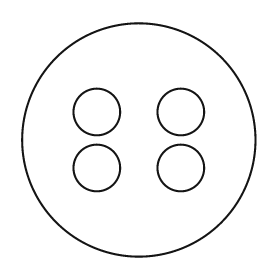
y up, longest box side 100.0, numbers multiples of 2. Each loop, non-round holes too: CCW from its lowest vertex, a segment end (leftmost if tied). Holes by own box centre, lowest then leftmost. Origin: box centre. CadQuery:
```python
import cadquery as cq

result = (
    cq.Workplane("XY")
    .moveTo(0.0, 0.0)
    .circle(50.0)
    .moveTo(-18.0, -12.0)
    .circle(10.0)
    .moveTo(18.0, -12.0)
    .circle(10.0)
    .moveTo(-18.0, 12.0)
    .circle(10.0)
    .moveTo(18.0, 12.0)
    .circle(10.0)
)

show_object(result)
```